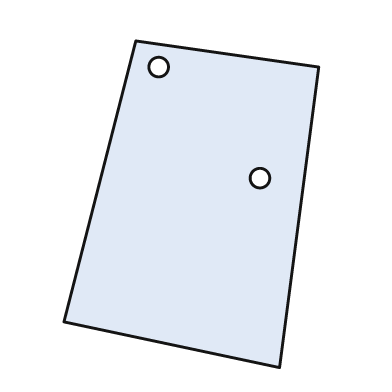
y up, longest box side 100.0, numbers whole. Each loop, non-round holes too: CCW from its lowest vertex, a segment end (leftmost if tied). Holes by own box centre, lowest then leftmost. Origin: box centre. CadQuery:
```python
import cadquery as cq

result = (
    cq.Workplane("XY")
    .moveTo(27.0, -50.0)
    .lineTo(39.0, 42.0)
    .lineTo(-17.0, 50.0)
    .lineTo(-39.0, -36.0)
    .close()
    .moveTo(21.0, 8.0)
    .circle(3.0)
    .moveTo(-10.0, 42.0)
    .circle(3.0)
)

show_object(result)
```